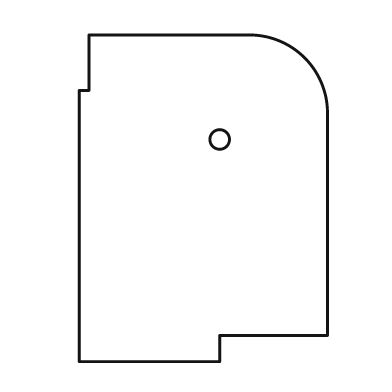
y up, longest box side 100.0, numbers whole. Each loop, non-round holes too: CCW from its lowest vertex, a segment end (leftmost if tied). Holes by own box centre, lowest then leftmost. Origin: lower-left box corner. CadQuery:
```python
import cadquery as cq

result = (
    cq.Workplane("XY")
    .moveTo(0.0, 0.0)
    .lineTo(43.0, 0.0)
    .lineTo(43.0, 8.0)
    .lineTo(76.0, 8.0)
    .lineTo(76.0, 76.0)
    .threePointArc((69.0, 93.0), (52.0, 100.0))
    .lineTo(3.0, 100.0)
    .lineTo(3.0, 83.0)
    .lineTo(0.0, 83.0)
    .close()
    .moveTo(43.0, 68.0)
    .circle(3.0)
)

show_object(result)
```